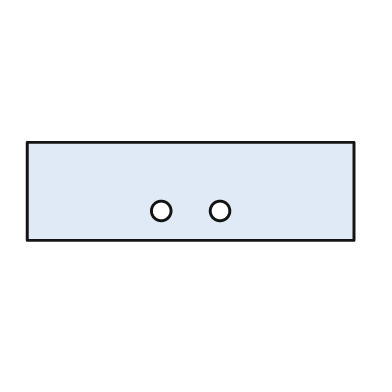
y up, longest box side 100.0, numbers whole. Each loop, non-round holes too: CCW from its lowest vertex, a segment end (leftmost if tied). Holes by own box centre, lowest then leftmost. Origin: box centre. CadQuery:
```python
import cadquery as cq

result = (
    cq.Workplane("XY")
    .moveTo(-50.0, -15.0)
    .lineTo(50.0, -15.0)
    .lineTo(50.0, 15.0)
    .lineTo(-50.0, 15.0)
    .close()
    .moveTo(-9.0, -6.0)
    .circle(3.0)
    .moveTo(9.0, -6.0)
    .circle(3.0)
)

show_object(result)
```